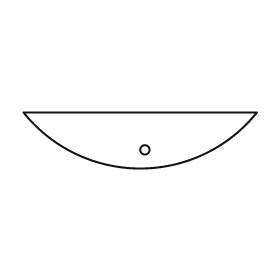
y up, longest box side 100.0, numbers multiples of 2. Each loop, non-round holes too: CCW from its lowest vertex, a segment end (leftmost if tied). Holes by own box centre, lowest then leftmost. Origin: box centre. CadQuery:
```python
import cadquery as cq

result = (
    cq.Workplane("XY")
    .moveTo(-50.0, 12.0)
    .threePointArc((0.0, -12.0), (50.0, 12.0))
    .close()
    .moveTo(2.0, -4.0)
    .circle(2.0)
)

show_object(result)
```